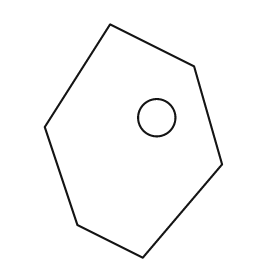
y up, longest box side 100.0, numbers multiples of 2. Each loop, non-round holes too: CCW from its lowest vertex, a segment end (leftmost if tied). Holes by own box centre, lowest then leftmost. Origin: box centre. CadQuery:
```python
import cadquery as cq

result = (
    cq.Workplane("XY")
    .moveTo(4.0, -50.0)
    .lineTo(38.0, -10.0)
    .lineTo(26.0, 32.0)
    .lineTo(-10.0, 50.0)
    .lineTo(-38.0, 6.0)
    .lineTo(-24.0, -36.0)
    .close()
    .moveTo(10.0, 10.0)
    .circle(8.0)
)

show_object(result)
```